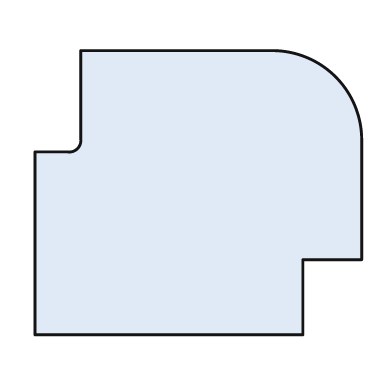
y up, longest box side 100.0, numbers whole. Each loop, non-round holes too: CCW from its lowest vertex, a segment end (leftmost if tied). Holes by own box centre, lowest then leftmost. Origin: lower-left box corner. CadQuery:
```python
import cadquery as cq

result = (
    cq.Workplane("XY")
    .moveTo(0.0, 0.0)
    .lineTo(82.0, 0.0)
    .lineTo(82.0, 23.0)
    .lineTo(100.0, 23.0)
    .lineTo(100.0, 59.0)
    .threePointArc((92.0, 79.0), (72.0, 87.0))
    .lineTo(14.0, 87.0)
    .lineTo(14.0, 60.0)
    .threePointArc((13.0, 57.0), (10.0, 56.0))
    .lineTo(0.0, 56.0)
    .close()
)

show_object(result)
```